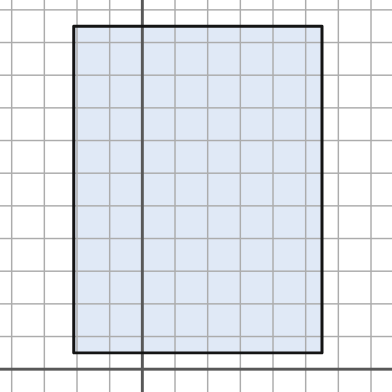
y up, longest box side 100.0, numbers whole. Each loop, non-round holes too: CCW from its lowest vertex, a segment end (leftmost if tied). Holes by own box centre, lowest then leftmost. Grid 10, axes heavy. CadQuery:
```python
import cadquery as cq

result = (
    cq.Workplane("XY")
    .moveTo(-21.0, 5.0)
    .lineTo(55.0, 5.0)
    .lineTo(55.0, 105.0)
    .lineTo(-21.0, 105.0)
    .close()
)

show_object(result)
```